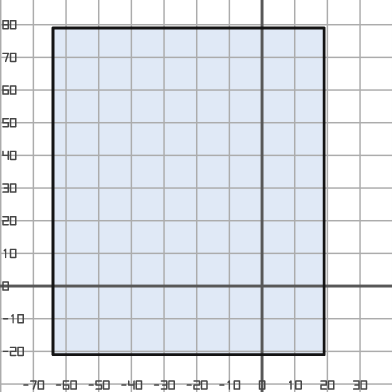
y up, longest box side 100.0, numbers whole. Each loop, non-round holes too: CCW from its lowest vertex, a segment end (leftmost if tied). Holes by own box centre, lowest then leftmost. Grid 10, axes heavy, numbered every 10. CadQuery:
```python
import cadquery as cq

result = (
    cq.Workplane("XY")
    .moveTo(-64.0, -21.0)
    .lineTo(19.0, -21.0)
    .lineTo(19.0, 79.0)
    .lineTo(-64.0, 79.0)
    .close()
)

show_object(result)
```